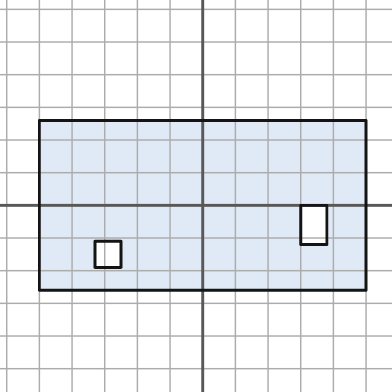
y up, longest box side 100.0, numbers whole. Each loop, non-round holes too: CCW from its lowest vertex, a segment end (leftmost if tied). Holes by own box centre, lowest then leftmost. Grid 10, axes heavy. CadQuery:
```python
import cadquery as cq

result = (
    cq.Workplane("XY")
    .moveTo(-50.0, -26.0)
    .lineTo(50.0, -26.0)
    .lineTo(50.0, 26.0)
    .lineTo(-50.0, 26.0)
    .close()
    .moveTo(-33.0, -19.0)
    .lineTo(-25.0, -19.0)
    .lineTo(-25.0, -11.0)
    .lineTo(-33.0, -11.0)
    .close()
    .moveTo(30.0, -12.0)
    .lineTo(38.0, -12.0)
    .lineTo(38.0, 0.0)
    .lineTo(30.0, 0.0)
    .close()
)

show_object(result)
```